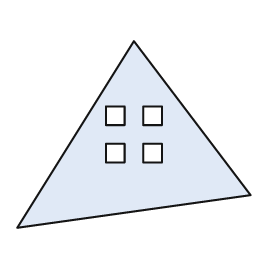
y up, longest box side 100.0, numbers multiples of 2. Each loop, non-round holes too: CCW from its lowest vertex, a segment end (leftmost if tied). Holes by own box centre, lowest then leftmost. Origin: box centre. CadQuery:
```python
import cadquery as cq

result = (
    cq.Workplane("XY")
    .moveTo(-50.0, -40.0)
    .lineTo(50.0, -26.0)
    .lineTo(0.0, 40.0)
    .close()
    .moveTo(-12.0, -12.0)
    .lineTo(-4.0, -12.0)
    .lineTo(-4.0, -4.0)
    .lineTo(-12.0, -4.0)
    .close()
    .moveTo(4.0, -12.0)
    .lineTo(12.0, -12.0)
    .lineTo(12.0, -4.0)
    .lineTo(4.0, -4.0)
    .close()
    .moveTo(-12.0, 4.0)
    .lineTo(-4.0, 4.0)
    .lineTo(-4.0, 12.0)
    .lineTo(-12.0, 12.0)
    .close()
    .moveTo(4.0, 4.0)
    .lineTo(12.0, 4.0)
    .lineTo(12.0, 12.0)
    .lineTo(4.0, 12.0)
    .close()
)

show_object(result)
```